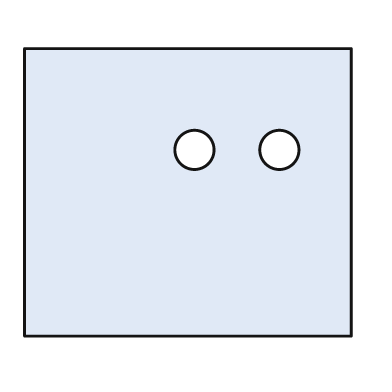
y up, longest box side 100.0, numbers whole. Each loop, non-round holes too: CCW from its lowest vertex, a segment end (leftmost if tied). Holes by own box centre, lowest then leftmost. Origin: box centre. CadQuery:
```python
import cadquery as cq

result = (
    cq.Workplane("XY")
    .moveTo(-50.0, -44.0)
    .lineTo(50.0, -44.0)
    .lineTo(50.0, 44.0)
    .lineTo(-50.0, 44.0)
    .close()
    .moveTo(2.0, 13.0)
    .circle(6.0)
    .moveTo(28.0, 13.0)
    .circle(6.0)
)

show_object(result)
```